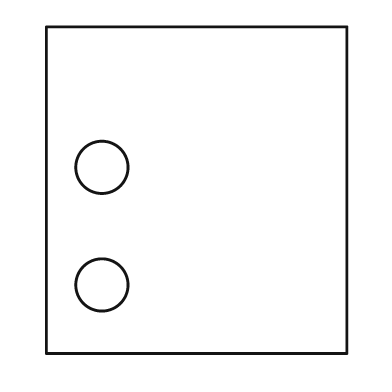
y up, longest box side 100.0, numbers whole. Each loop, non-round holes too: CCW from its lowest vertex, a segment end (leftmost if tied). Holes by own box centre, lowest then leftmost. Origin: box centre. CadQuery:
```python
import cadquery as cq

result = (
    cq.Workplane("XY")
    .moveTo(-46.0, -50.0)
    .lineTo(46.0, -50.0)
    .lineTo(46.0, 50.0)
    .lineTo(-46.0, 50.0)
    .close()
    .moveTo(-29.0, -29.0)
    .circle(8.0)
    .moveTo(-29.0, 7.0)
    .circle(8.0)
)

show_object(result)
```